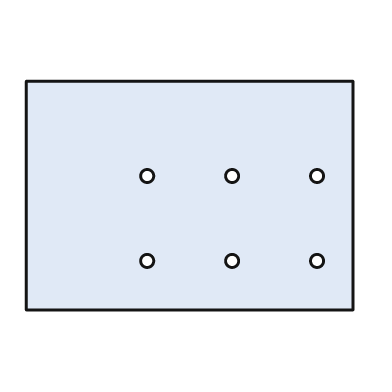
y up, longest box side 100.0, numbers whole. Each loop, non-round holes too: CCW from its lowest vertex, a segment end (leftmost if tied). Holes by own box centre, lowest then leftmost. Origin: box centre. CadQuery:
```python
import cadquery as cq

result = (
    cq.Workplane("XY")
    .moveTo(-50.0, -35.0)
    .lineTo(50.0, -35.0)
    .lineTo(50.0, 35.0)
    .lineTo(-50.0, 35.0)
    .close()
    .moveTo(-13.0, -20.0)
    .circle(2.0)
    .moveTo(13.0, -20.0)
    .circle(2.0)
    .moveTo(39.0, -20.0)
    .circle(2.0)
    .moveTo(-13.0, 6.0)
    .circle(2.0)
    .moveTo(13.0, 6.0)
    .circle(2.0)
    .moveTo(39.0, 6.0)
    .circle(2.0)
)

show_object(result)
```